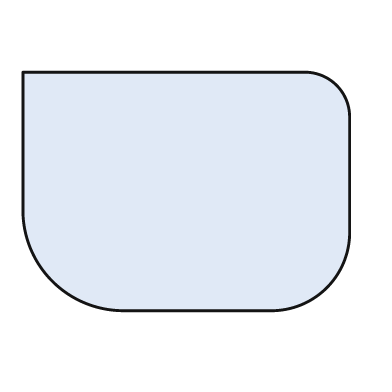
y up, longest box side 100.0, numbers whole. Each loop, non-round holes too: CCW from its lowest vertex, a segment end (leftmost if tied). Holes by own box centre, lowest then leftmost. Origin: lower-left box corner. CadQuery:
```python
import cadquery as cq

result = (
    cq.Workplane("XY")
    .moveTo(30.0, 0.0)
    .lineTo(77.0, 0.0)
    .threePointArc((93.0, 7.0), (100.0, 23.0))
    .lineTo(100.0, 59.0)
    .threePointArc((96.0, 69.0), (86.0, 73.0))
    .lineTo(0.0, 73.0)
    .lineTo(0.0, 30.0)
    .threePointArc((9.0, 9.0), (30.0, 0.0))
    .close()
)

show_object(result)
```